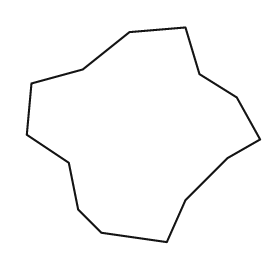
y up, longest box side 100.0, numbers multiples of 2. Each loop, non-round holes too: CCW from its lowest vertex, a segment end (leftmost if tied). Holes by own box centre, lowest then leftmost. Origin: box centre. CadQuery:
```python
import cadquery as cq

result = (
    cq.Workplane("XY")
    .moveTo(10.0, -46.0)
    .lineTo(18.0, -28.0)
    .lineTo(36.0, -10.0)
    .lineTo(50.0, -2.0)
    .lineTo(40.0, 16.0)
    .lineTo(24.0, 26.0)
    .lineTo(18.0, 46.0)
    .lineTo(-6.0, 44.0)
    .lineTo(-26.0, 28.0)
    .lineTo(-48.0, 22.0)
    .lineTo(-50.0, 0.0)
    .lineTo(-32.0, -12.0)
    .lineTo(-28.0, -32.0)
    .lineTo(-18.0, -42.0)
    .close()
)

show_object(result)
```